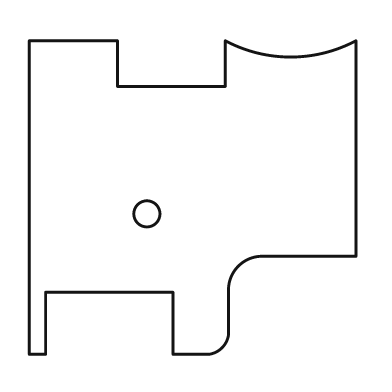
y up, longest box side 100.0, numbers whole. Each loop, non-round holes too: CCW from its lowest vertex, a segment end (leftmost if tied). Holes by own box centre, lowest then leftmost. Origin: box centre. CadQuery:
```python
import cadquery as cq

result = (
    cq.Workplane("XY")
    .moveTo(-50.0, -48.0)
    .lineTo(-45.0, -48.0)
    .lineTo(-45.0, -29.0)
    .lineTo(-6.0, -29.0)
    .lineTo(-6.0, -48.0)
    .lineTo(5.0, -48.0)
    .threePointArc((9.0, -46.0), (11.0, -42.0))
    .lineTo(11.0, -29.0)
    .threePointArc((14.0, -21.0), (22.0, -18.0))
    .lineTo(50.0, -18.0)
    .lineTo(50.0, 48.0)
    .threePointArc((30.0, 43.0), (10.0, 48.0))
    .lineTo(10.0, 34.0)
    .lineTo(-23.0, 34.0)
    .lineTo(-23.0, 48.0)
    .lineTo(-50.0, 48.0)
    .close()
    .moveTo(-14.0, -5.0)
    .circle(4.0)
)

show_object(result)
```